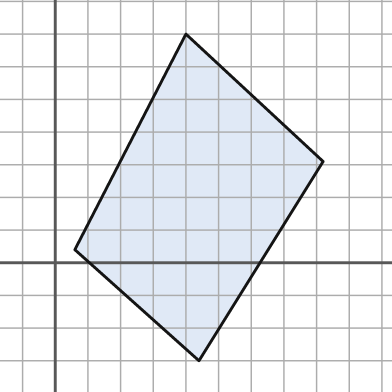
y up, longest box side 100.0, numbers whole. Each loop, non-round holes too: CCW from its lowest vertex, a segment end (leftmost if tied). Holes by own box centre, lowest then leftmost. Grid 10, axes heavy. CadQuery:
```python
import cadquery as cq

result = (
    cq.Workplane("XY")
    .moveTo(44.0, -30.0)
    .lineTo(82.0, 31.0)
    .lineTo(40.0, 70.0)
    .lineTo(6.0, 4.0)
    .close()
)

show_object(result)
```